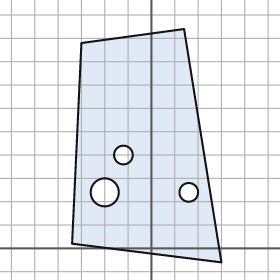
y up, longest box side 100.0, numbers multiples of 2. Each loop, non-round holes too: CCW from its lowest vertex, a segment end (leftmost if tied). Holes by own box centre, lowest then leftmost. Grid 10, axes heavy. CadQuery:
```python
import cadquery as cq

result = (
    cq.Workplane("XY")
    .moveTo(30.0, -6.0)
    .lineTo(14.0, 94.0)
    .lineTo(-30.0, 88.0)
    .lineTo(-34.0, 2.0)
    .close()
    .moveTo(-20.0, 24.0)
    .circle(6.0)
    .moveTo(16.0, 24.0)
    .circle(4.0)
    .moveTo(-12.0, 40.0)
    .circle(4.0)
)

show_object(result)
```